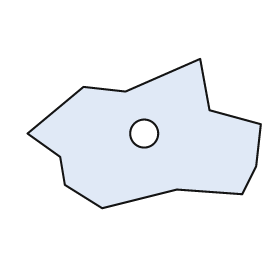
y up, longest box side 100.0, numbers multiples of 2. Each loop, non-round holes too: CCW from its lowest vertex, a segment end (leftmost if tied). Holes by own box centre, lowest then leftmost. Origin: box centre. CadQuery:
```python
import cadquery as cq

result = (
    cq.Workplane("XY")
    .moveTo(-18.0, -32.0)
    .lineTo(14.0, -24.0)
    .lineTo(42.0, -26.0)
    .lineTo(48.0, -14.0)
    .lineTo(50.0, 4.0)
    .lineTo(28.0, 10.0)
    .lineTo(24.0, 32.0)
    .lineTo(-8.0, 18.0)
    .lineTo(-26.0, 20.0)
    .lineTo(-50.0, 0.0)
    .lineTo(-36.0, -10.0)
    .lineTo(-34.0, -22.0)
    .close()
    .moveTo(0.0, 0.0)
    .circle(6.0)
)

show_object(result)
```